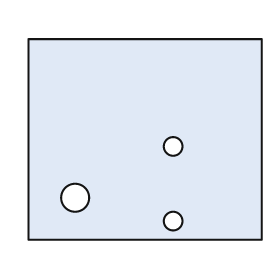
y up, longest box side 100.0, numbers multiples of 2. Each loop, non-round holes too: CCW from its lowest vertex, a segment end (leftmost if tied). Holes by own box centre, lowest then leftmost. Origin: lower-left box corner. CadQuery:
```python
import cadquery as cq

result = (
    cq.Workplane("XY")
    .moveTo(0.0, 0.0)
    .lineTo(100.0, 0.0)
    .lineTo(100.0, 86.0)
    .lineTo(0.0, 86.0)
    .close()
    .moveTo(62.0, 8.0)
    .circle(4.0)
    .moveTo(20.0, 18.0)
    .circle(6.0)
    .moveTo(62.0, 40.0)
    .circle(4.0)
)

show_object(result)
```